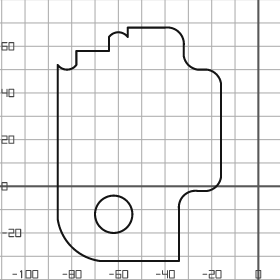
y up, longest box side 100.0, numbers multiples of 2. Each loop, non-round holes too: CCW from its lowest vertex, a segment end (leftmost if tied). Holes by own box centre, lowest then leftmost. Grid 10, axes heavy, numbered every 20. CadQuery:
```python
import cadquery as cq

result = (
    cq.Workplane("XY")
    .moveTo(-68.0, -32.0)
    .lineTo(-34.0, -32.0)
    .lineTo(-34.0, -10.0)
    .threePointArc((-32.0, -4.0), (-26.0, -2.0))
    .lineTo(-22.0, -2.0)
    .threePointArc((-18.0, 0.0), (-16.0, 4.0))
    .lineTo(-16.0, 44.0)
    .threePointArc((-18.0, 48.0), (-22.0, 50.0))
    .lineTo(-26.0, 50.0)
    .threePointArc((-30.0, 52.0), (-32.0, 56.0))
    .lineTo(-32.0, 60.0)
    .threePointArc((-34.0, 66.0), (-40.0, 68.0))
    .lineTo(-56.0, 68.0)
    .lineTo(-56.0, 64.0)
    .threePointArc((-60.0, 66.0), (-64.0, 64.0))
    .lineTo(-64.0, 58.0)
    .lineTo(-78.0, 58.0)
    .lineTo(-78.0, 52.0)
    .threePointArc((-82.0, 50.0), (-86.0, 52.0))
    .lineTo(-86.0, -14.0)
    .threePointArc((-80.0, -26.0), (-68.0, -32.0))
    .close()
    .moveTo(-62.0, -12.0)
    .circle(8.0)
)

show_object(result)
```